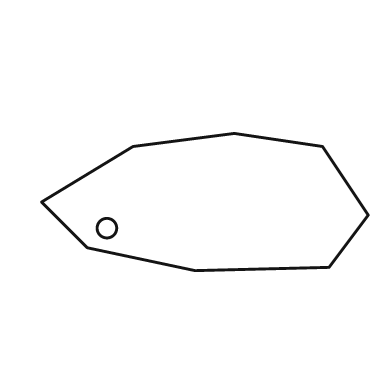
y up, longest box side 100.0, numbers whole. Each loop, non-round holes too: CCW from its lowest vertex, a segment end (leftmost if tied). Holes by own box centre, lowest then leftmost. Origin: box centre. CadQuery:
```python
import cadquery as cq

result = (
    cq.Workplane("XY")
    .moveTo(-3.0, -21.0)
    .lineTo(38.0, -20.0)
    .lineTo(50.0, -4.0)
    .lineTo(36.0, 17.0)
    .lineTo(9.0, 21.0)
    .lineTo(-22.0, 17.0)
    .lineTo(-50.0, 0.0)
    .lineTo(-36.0, -14.0)
    .close()
    .moveTo(-30.0, -8.0)
    .circle(3.0)
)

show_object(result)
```